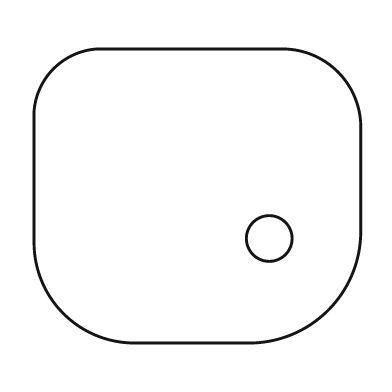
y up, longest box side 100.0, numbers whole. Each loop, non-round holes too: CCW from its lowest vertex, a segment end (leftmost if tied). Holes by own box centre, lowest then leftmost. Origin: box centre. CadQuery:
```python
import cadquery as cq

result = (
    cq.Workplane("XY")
    .moveTo(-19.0, -45.0)
    .lineTo(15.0, -45.0)
    .threePointArc((40.0, -35.0), (50.0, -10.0))
    .lineTo(50.0, 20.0)
    .threePointArc((43.0, 38.0), (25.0, 45.0))
    .lineTo(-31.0, 45.0)
    .threePointArc((-44.0, 39.0), (-50.0, 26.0))
    .lineTo(-50.0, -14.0)
    .threePointArc((-41.0, -36.0), (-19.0, -45.0))
    .close()
    .moveTo(22.0, -13.0)
    .circle(7.0)
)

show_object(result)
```